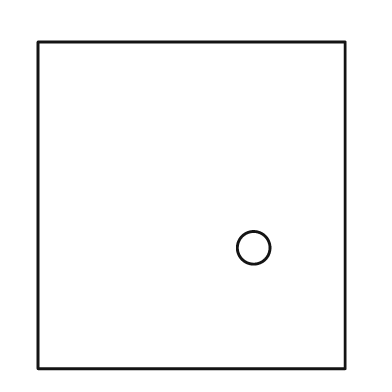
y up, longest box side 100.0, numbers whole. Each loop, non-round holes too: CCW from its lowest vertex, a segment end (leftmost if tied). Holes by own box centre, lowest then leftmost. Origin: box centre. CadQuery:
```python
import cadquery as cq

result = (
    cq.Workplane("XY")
    .moveTo(-47.0, -50.0)
    .lineTo(47.0, -50.0)
    .lineTo(47.0, 50.0)
    .lineTo(-47.0, 50.0)
    .close()
    .moveTo(19.0, -13.0)
    .circle(5.0)
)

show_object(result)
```